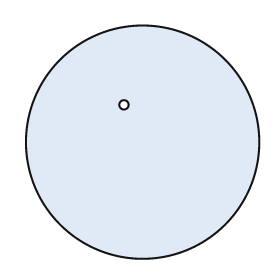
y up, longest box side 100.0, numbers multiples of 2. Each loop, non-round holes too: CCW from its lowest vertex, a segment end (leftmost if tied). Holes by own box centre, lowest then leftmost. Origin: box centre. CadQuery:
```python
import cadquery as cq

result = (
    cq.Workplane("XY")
    .moveTo(0.0, 0.0)
    .circle(50.0)
    .moveTo(-8.0, 16.0)
    .circle(2.0)
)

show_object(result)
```